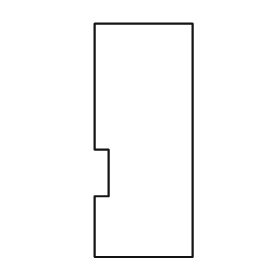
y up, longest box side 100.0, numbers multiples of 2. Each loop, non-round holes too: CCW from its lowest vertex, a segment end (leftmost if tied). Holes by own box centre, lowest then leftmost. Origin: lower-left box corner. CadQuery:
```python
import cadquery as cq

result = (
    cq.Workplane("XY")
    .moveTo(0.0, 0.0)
    .lineTo(42.0, 0.0)
    .lineTo(42.0, 100.0)
    .lineTo(0.0, 100.0)
    .lineTo(0.0, 46.0)
    .lineTo(6.0, 46.0)
    .lineTo(6.0, 26.0)
    .lineTo(0.0, 26.0)
    .close()
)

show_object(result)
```